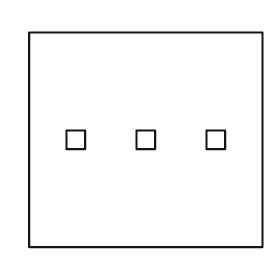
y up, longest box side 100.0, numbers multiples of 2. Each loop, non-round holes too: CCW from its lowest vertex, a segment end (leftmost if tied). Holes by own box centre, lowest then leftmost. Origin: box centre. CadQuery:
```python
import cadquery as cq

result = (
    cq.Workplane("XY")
    .moveTo(-50.0, -46.0)
    .lineTo(50.0, -46.0)
    .lineTo(50.0, 46.0)
    .lineTo(-50.0, 46.0)
    .close()
    .moveTo(-34.0, -4.0)
    .lineTo(-26.0, -4.0)
    .lineTo(-26.0, 4.0)
    .lineTo(-34.0, 4.0)
    .close()
    .moveTo(-4.0, -4.0)
    .lineTo(4.0, -4.0)
    .lineTo(4.0, 4.0)
    .lineTo(-4.0, 4.0)
    .close()
    .moveTo(26.0, -4.0)
    .lineTo(34.0, -4.0)
    .lineTo(34.0, 4.0)
    .lineTo(26.0, 4.0)
    .close()
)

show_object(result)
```